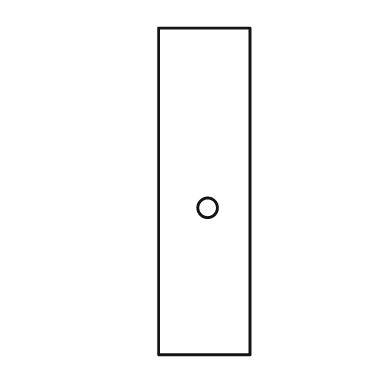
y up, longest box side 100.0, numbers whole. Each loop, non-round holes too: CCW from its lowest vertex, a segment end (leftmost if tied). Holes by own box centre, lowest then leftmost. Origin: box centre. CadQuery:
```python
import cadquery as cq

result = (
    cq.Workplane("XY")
    .moveTo(-14.0, -50.0)
    .lineTo(14.0, -50.0)
    .lineTo(14.0, 50.0)
    .lineTo(-14.0, 50.0)
    .close()
    .moveTo(1.0, -5.0)
    .circle(3.0)
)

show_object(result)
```